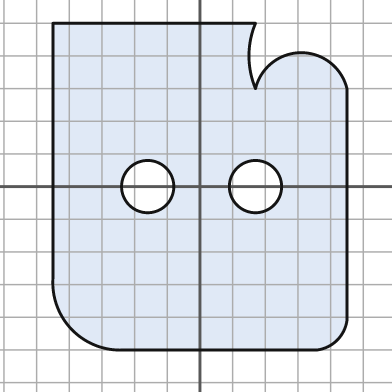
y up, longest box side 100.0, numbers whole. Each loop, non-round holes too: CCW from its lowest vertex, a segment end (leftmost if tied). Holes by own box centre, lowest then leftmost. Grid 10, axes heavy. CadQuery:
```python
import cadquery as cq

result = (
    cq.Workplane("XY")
    .moveTo(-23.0, -50.0)
    .lineTo(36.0, -50.0)
    .threePointArc((42.0, -47.0), (45.0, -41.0))
    .lineTo(45.0, 30.0)
    .threePointArc((31.0, 41.0), (17.0, 30.0))
    .threePointArc((15.0, 40.0), (17.0, 50.0))
    .lineTo(-45.0, 50.0)
    .lineTo(-45.0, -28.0)
    .threePointArc((-39.0, -44.0), (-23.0, -50.0))
    .close()
    .moveTo(-16.0, 0.0)
    .circle(8.0)
    .moveTo(17.0, 0.0)
    .circle(8.0)
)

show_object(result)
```